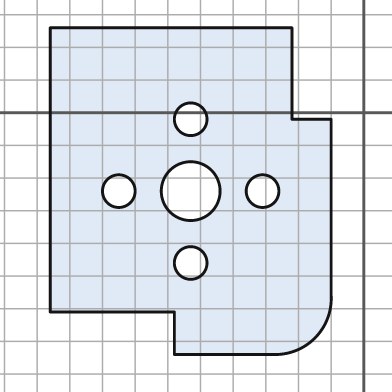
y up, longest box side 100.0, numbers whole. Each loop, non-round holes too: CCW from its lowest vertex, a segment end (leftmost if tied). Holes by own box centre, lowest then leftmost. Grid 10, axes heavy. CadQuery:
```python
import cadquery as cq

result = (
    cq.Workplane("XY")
    .moveTo(-58.0, -74.0)
    .lineTo(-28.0, -74.0)
    .threePointArc((-15.0, -69.0), (-10.0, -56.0))
    .lineTo(-10.0, -2.0)
    .lineTo(-22.0, -2.0)
    .lineTo(-22.0, 26.0)
    .lineTo(-96.0, 26.0)
    .lineTo(-96.0, -61.0)
    .lineTo(-58.0, -61.0)
    .close()
    .moveTo(-53.0, -46.0)
    .circle(5.0)
    .moveTo(-75.0, -24.0)
    .circle(5.0)
    .moveTo(-53.0, -24.0)
    .circle(9.0)
    .moveTo(-31.0, -24.0)
    .circle(5.0)
    .moveTo(-53.0, -2.0)
    .circle(5.0)
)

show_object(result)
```